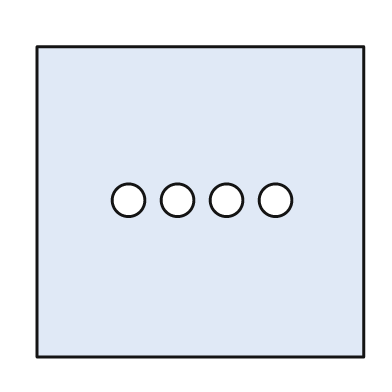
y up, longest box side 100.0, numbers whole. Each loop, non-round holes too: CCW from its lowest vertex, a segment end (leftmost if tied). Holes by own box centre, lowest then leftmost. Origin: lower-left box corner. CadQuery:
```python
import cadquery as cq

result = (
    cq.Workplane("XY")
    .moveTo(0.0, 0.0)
    .lineTo(100.0, 0.0)
    .lineTo(100.0, 95.0)
    .lineTo(0.0, 95.0)
    .close()
    .moveTo(28.0, 48.0)
    .circle(5.0)
    .moveTo(43.0, 48.0)
    .circle(5.0)
    .moveTo(58.0, 48.0)
    .circle(5.0)
    .moveTo(73.0, 48.0)
    .circle(5.0)
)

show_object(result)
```